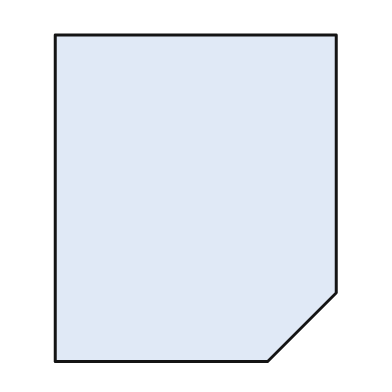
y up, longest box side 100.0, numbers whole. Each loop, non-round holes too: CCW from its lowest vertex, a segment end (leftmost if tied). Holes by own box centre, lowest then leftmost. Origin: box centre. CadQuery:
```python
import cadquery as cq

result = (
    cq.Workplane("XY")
    .moveTo(-43.0, -50.0)
    .lineTo(22.0, -50.0)
    .lineTo(43.0, -29.0)
    .lineTo(43.0, 50.0)
    .lineTo(-43.0, 50.0)
    .close()
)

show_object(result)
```